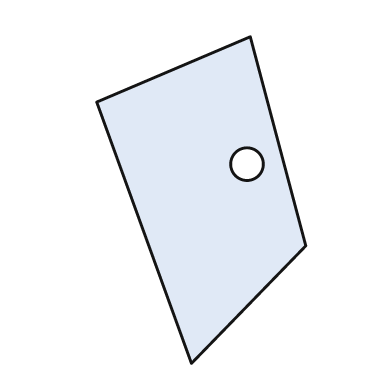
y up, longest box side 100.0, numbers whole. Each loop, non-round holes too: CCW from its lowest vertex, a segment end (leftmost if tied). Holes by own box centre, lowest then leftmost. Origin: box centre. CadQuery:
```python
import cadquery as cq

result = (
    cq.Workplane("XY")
    .moveTo(-3.0, -50.0)
    .lineTo(32.0, -14.0)
    .lineTo(15.0, 50.0)
    .lineTo(-32.0, 30.0)
    .close()
    .moveTo(14.0, 11.0)
    .circle(5.0)
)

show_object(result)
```